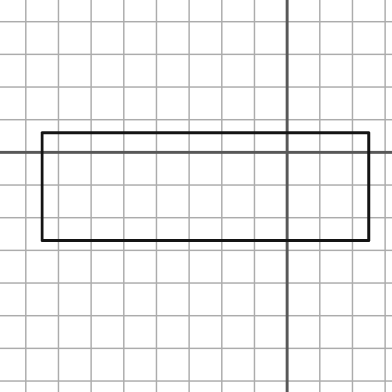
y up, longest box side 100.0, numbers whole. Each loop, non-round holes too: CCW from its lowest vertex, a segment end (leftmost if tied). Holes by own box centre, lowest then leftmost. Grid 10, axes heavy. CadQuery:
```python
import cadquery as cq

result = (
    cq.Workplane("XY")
    .moveTo(-75.0, -27.0)
    .lineTo(25.0, -27.0)
    .lineTo(25.0, 6.0)
    .lineTo(-75.0, 6.0)
    .close()
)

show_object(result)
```